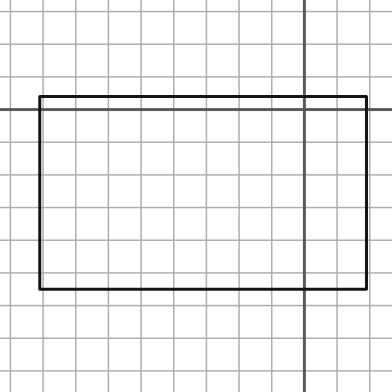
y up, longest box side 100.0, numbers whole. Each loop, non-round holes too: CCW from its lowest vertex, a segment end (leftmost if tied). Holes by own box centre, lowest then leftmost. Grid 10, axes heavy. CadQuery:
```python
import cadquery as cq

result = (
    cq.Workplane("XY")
    .moveTo(-81.0, -55.0)
    .lineTo(19.0, -55.0)
    .lineTo(19.0, 4.0)
    .lineTo(-81.0, 4.0)
    .close()
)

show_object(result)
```